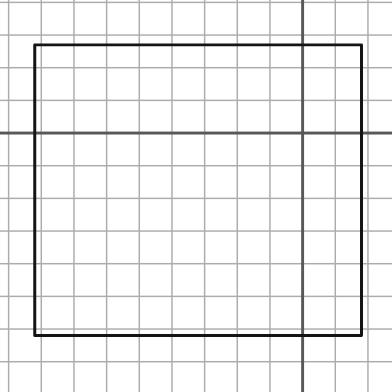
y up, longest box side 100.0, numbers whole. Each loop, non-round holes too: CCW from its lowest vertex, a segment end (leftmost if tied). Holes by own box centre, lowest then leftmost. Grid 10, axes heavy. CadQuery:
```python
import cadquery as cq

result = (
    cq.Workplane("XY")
    .moveTo(-82.0, -62.0)
    .lineTo(18.0, -62.0)
    .lineTo(18.0, 27.0)
    .lineTo(-82.0, 27.0)
    .close()
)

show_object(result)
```